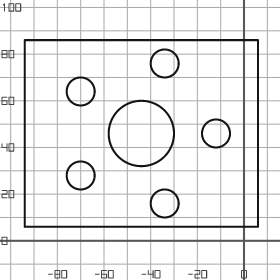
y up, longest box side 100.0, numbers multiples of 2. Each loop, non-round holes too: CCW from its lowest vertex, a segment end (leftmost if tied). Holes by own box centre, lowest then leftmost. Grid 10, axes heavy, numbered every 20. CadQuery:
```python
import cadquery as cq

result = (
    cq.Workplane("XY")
    .moveTo(-94.0, 6.0)
    .lineTo(6.0, 6.0)
    .lineTo(6.0, 86.0)
    .lineTo(-94.0, 86.0)
    .close()
    .moveTo(-34.0, 16.0)
    .circle(6.0)
    .moveTo(-70.0, 28.0)
    .circle(6.0)
    .moveTo(-44.0, 46.0)
    .circle(14.0)
    .moveTo(-12.0, 46.0)
    .circle(6.0)
    .moveTo(-70.0, 64.0)
    .circle(6.0)
    .moveTo(-34.0, 76.0)
    .circle(6.0)
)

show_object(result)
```